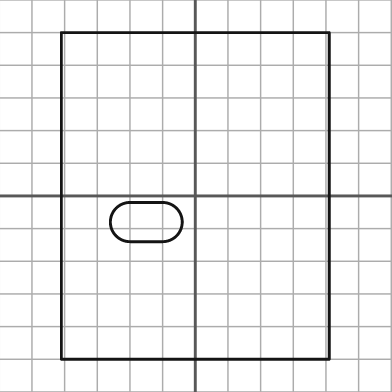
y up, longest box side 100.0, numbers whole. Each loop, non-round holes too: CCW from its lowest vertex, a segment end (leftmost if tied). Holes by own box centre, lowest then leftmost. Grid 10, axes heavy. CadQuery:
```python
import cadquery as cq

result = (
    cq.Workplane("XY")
    .moveTo(-41.0, -50.0)
    .lineTo(41.0, -50.0)
    .lineTo(41.0, 50.0)
    .lineTo(-41.0, 50.0)
    .close()
    .moveTo(-20.0, -14.0)
    .lineTo(-10.0, -14.0)
    .threePointArc((-4.0, -8.0), (-10.0, -2.0))
    .lineTo(-20.0, -2.0)
    .threePointArc((-26.0, -8.0), (-20.0, -14.0))
    .close()
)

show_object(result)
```